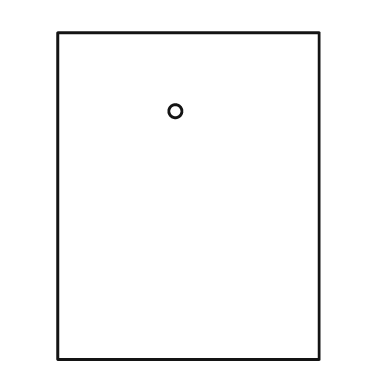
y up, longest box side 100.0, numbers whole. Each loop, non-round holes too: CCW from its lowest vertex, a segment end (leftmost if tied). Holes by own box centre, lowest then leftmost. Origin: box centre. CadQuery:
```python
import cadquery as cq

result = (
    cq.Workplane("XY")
    .moveTo(-40.0, -50.0)
    .lineTo(40.0, -50.0)
    .lineTo(40.0, 50.0)
    .lineTo(-40.0, 50.0)
    .close()
    .moveTo(-4.0, 26.0)
    .circle(2.0)
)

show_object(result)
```